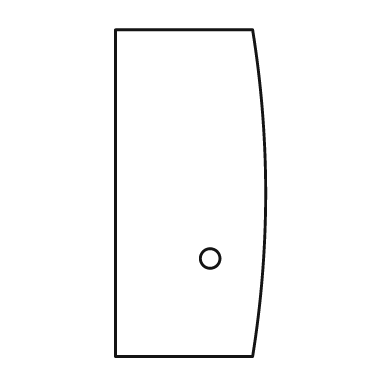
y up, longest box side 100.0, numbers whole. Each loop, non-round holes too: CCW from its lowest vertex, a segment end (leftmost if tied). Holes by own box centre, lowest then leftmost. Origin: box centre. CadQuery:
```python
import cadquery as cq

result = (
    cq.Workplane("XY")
    .moveTo(-23.0, -50.0)
    .lineTo(19.0, -50.0)
    .threePointArc((23.0, 0.0), (19.0, 50.0))
    .lineTo(-23.0, 50.0)
    .close()
    .moveTo(6.0, -20.0)
    .circle(3.0)
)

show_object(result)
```